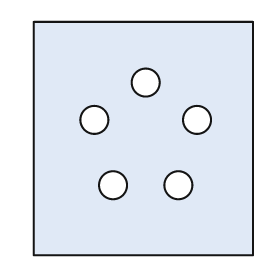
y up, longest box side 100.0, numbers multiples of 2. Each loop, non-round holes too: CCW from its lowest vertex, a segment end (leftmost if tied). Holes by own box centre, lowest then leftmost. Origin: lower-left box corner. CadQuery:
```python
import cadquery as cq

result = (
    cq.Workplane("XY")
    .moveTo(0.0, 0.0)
    .lineTo(94.0, 0.0)
    .lineTo(94.0, 100.0)
    .lineTo(0.0, 100.0)
    .close()
    .moveTo(34.0, 30.0)
    .circle(6.0)
    .moveTo(62.0, 30.0)
    .circle(6.0)
    .moveTo(26.0, 58.0)
    .circle(6.0)
    .moveTo(70.0, 58.0)
    .circle(6.0)
    .moveTo(48.0, 74.0)
    .circle(6.0)
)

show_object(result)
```